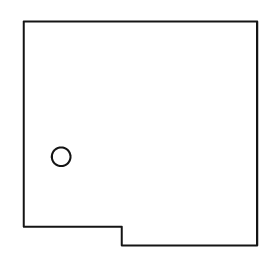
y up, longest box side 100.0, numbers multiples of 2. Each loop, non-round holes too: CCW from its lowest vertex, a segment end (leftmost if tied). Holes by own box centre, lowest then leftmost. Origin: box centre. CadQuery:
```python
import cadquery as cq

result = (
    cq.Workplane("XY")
    .moveTo(-8.0, -48.0)
    .lineTo(50.0, -48.0)
    .lineTo(50.0, 48.0)
    .lineTo(-50.0, 48.0)
    .lineTo(-50.0, -40.0)
    .lineTo(-8.0, -40.0)
    .close()
    .moveTo(-34.0, -10.0)
    .circle(4.0)
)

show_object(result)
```